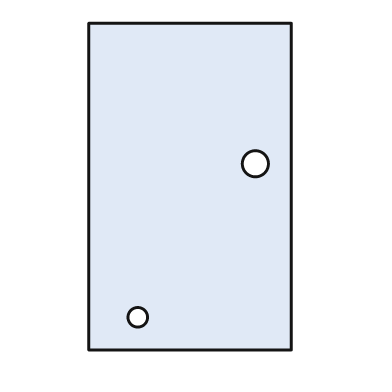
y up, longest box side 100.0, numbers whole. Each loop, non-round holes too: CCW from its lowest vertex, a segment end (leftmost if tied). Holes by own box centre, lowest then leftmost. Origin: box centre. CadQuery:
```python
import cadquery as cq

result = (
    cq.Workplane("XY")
    .moveTo(-31.0, -50.0)
    .lineTo(31.0, -50.0)
    .lineTo(31.0, 50.0)
    .lineTo(-31.0, 50.0)
    .close()
    .moveTo(-16.0, -40.0)
    .circle(3.0)
    .moveTo(20.0, 7.0)
    .circle(4.0)
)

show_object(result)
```